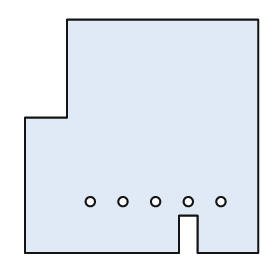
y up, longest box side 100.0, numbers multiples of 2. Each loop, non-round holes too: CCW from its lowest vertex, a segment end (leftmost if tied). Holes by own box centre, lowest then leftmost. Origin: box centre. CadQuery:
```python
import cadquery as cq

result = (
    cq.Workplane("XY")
    .moveTo(-50.0, -50.0)
    .lineTo(16.0, -50.0)
    .lineTo(16.0, -34.0)
    .lineTo(24.0, -34.0)
    .lineTo(24.0, -50.0)
    .lineTo(50.0, -50.0)
    .lineTo(50.0, 50.0)
    .lineTo(-32.0, 50.0)
    .lineTo(-32.0, 8.0)
    .lineTo(-50.0, 8.0)
    .close()
    .moveTo(-22.0, -28.0)
    .circle(2.0)
    .moveTo(-8.0, -28.0)
    .circle(2.0)
    .moveTo(6.0, -28.0)
    .circle(2.0)
    .moveTo(20.0, -28.0)
    .circle(2.0)
    .moveTo(34.0, -28.0)
    .circle(2.0)
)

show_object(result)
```